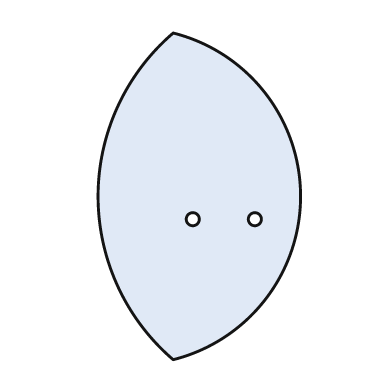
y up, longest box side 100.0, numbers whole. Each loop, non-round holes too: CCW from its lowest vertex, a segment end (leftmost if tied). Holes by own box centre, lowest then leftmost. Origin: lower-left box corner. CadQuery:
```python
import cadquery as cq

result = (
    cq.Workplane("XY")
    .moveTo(23.0, 0.0)
    .threePointArc((62.0, 50.0), (23.0, 100.0))
    .threePointArc((0.0, 50.0), (23.0, 0.0))
    .close()
    .moveTo(29.0, 43.0)
    .circle(2.0)
    .moveTo(48.0, 43.0)
    .circle(2.0)
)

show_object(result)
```